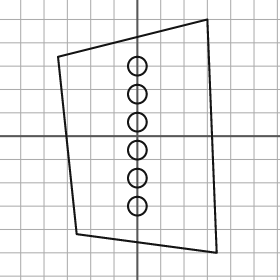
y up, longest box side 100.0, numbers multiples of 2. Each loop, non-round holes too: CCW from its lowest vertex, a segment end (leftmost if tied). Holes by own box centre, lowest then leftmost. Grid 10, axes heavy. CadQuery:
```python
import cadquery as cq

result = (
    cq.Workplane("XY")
    .moveTo(34.0, -50.0)
    .lineTo(30.0, 50.0)
    .lineTo(-34.0, 34.0)
    .lineTo(-26.0, -42.0)
    .close()
    .moveTo(0.0, -30.0)
    .circle(4.0)
    .moveTo(0.0, -18.0)
    .circle(4.0)
    .moveTo(0.0, -6.0)
    .circle(4.0)
    .moveTo(0.0, 6.0)
    .circle(4.0)
    .moveTo(0.0, 18.0)
    .circle(4.0)
    .moveTo(0.0, 30.0)
    .circle(4.0)
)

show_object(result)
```